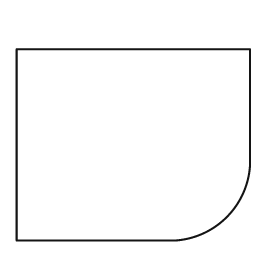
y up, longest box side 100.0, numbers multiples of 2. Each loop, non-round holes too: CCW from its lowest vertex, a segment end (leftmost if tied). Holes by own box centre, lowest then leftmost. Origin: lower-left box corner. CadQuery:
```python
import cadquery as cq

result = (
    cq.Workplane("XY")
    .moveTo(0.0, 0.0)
    .lineTo(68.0, 0.0)
    .threePointArc((90.0, 10.0), (100.0, 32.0))
    .lineTo(100.0, 82.0)
    .lineTo(0.0, 82.0)
    .close()
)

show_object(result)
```